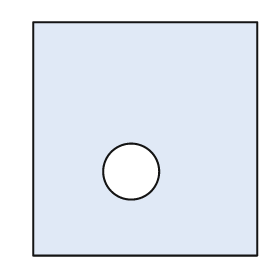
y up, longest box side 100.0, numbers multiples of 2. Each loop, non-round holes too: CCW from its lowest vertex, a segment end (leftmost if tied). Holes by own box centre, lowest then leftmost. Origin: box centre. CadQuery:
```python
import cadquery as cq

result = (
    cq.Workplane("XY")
    .moveTo(-48.0, -50.0)
    .lineTo(48.0, -50.0)
    .lineTo(48.0, 50.0)
    .lineTo(-48.0, 50.0)
    .close()
    .moveTo(-6.0, -14.0)
    .circle(12.0)
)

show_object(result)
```